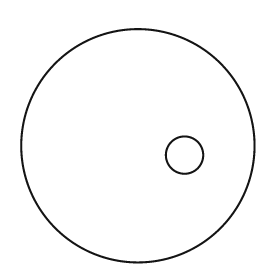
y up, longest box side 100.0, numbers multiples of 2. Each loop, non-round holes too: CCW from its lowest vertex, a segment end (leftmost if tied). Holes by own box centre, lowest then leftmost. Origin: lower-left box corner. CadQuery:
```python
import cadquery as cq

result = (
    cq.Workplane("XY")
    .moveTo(50.0, 50.0)
    .circle(50.0)
    .moveTo(70.0, 46.0)
    .circle(8.0)
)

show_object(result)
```